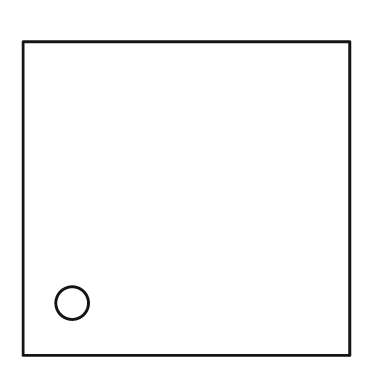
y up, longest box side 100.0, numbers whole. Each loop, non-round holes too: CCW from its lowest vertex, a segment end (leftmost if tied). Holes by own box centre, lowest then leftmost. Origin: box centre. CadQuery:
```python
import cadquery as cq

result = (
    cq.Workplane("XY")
    .moveTo(-50.0, -48.0)
    .lineTo(50.0, -48.0)
    .lineTo(50.0, 48.0)
    .lineTo(-50.0, 48.0)
    .close()
    .moveTo(-35.0, -32.0)
    .circle(5.0)
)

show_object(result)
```